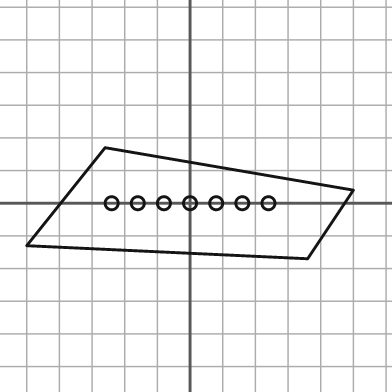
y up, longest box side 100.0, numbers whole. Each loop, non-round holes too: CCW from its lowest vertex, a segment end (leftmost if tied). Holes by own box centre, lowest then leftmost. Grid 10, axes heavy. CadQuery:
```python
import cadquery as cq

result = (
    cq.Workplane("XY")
    .moveTo(36.0, -17.0)
    .lineTo(50.0, 4.0)
    .lineTo(-26.0, 17.0)
    .lineTo(-50.0, -13.0)
    .close()
    .moveTo(-24.0, 0.0)
    .circle(2.0)
    .moveTo(-16.0, 0.0)
    .circle(2.0)
    .moveTo(-8.0, 0.0)
    .circle(2.0)
    .moveTo(0.0, 0.0)
    .circle(2.0)
    .moveTo(8.0, 0.0)
    .circle(2.0)
    .moveTo(16.0, 0.0)
    .circle(2.0)
    .moveTo(24.0, 0.0)
    .circle(2.0)
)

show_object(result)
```